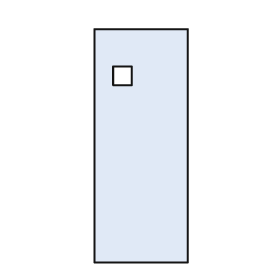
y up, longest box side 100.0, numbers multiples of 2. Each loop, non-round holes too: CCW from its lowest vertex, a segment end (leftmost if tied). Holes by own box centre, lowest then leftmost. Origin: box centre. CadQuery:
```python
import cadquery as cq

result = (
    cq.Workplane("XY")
    .moveTo(-20.0, -50.0)
    .lineTo(20.0, -50.0)
    .lineTo(20.0, 50.0)
    .lineTo(-20.0, 50.0)
    .close()
    .moveTo(-12.0, 26.0)
    .lineTo(-4.0, 26.0)
    .lineTo(-4.0, 34.0)
    .lineTo(-12.0, 34.0)
    .close()
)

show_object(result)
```